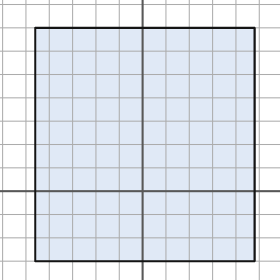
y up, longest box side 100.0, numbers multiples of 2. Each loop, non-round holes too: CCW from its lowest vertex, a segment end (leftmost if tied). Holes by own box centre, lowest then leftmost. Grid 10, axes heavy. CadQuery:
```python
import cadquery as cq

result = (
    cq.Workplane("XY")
    .moveTo(-46.0, -30.0)
    .lineTo(48.0, -30.0)
    .lineTo(48.0, 70.0)
    .lineTo(-46.0, 70.0)
    .close()
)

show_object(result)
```